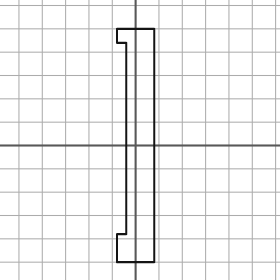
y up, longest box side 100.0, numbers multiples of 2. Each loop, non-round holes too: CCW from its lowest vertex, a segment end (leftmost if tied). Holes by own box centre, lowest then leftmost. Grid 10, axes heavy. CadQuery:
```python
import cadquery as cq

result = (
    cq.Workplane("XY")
    .moveTo(-8.0, -50.0)
    .lineTo(8.0, -50.0)
    .lineTo(8.0, 50.0)
    .lineTo(-8.0, 50.0)
    .lineTo(-8.0, 44.0)
    .lineTo(-4.0, 44.0)
    .lineTo(-4.0, -38.0)
    .lineTo(-8.0, -38.0)
    .close()
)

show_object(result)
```